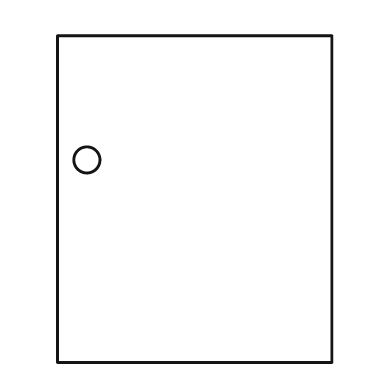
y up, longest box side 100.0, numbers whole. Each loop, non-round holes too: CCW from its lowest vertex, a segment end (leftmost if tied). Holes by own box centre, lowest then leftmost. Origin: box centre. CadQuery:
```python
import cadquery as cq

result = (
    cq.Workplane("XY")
    .moveTo(-42.0, -50.0)
    .lineTo(42.0, -50.0)
    .lineTo(42.0, 50.0)
    .lineTo(-42.0, 50.0)
    .close()
    .moveTo(-33.0, 12.0)
    .circle(4.0)
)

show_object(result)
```